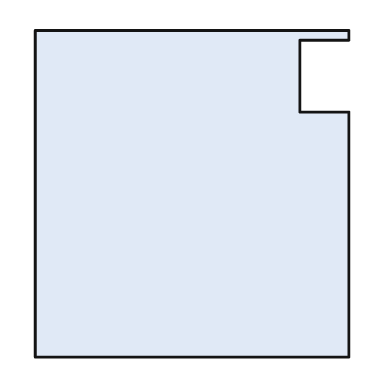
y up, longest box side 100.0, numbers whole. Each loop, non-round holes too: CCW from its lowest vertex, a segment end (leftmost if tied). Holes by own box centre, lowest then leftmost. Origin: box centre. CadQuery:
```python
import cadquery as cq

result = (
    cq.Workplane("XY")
    .moveTo(-48.0, -50.0)
    .lineTo(48.0, -50.0)
    .lineTo(48.0, 25.0)
    .lineTo(33.0, 25.0)
    .lineTo(33.0, 47.0)
    .lineTo(48.0, 47.0)
    .lineTo(48.0, 50.0)
    .lineTo(-48.0, 50.0)
    .close()
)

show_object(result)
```